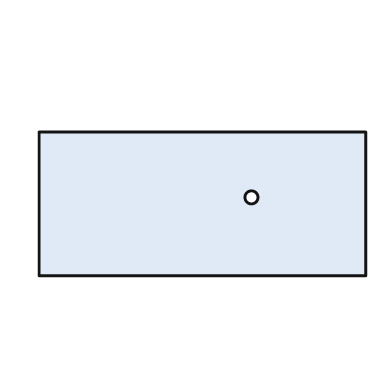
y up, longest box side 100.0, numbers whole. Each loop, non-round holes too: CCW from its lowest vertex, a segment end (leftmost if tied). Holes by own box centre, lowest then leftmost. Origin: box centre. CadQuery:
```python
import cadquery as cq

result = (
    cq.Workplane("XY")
    .moveTo(-50.0, -22.0)
    .lineTo(50.0, -22.0)
    .lineTo(50.0, 22.0)
    .lineTo(-50.0, 22.0)
    .close()
    .moveTo(15.0, 2.0)
    .circle(2.0)
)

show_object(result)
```